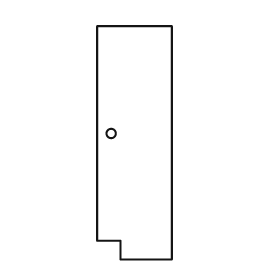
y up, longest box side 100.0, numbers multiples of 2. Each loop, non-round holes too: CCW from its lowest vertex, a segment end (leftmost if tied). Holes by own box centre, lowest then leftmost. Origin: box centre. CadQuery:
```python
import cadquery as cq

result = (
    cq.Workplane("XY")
    .moveTo(-6.0, -50.0)
    .lineTo(16.0, -50.0)
    .lineTo(16.0, 50.0)
    .lineTo(-16.0, 50.0)
    .lineTo(-16.0, -42.0)
    .lineTo(-6.0, -42.0)
    .close()
    .moveTo(-10.0, 4.0)
    .circle(2.0)
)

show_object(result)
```